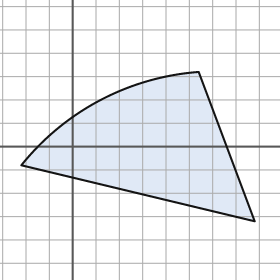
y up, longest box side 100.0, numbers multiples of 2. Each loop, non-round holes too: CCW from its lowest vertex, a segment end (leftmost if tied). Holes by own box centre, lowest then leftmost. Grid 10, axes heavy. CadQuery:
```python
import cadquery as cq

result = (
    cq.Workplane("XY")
    .moveTo(78.0, -32.0)
    .lineTo(54.0, 32.0)
    .threePointArc((12.0, 20.0), (-22.0, -8.0))
    .close()
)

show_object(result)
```